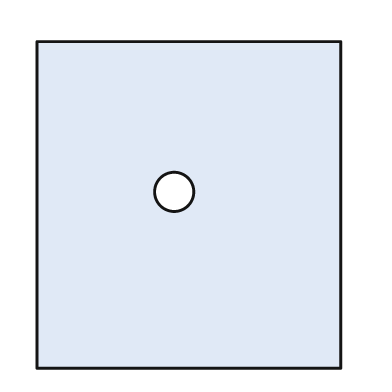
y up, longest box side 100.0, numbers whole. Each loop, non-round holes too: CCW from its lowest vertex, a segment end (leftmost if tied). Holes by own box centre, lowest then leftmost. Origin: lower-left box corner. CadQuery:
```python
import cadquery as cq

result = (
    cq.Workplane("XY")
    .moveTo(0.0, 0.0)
    .lineTo(93.0, 0.0)
    .lineTo(93.0, 100.0)
    .lineTo(0.0, 100.0)
    .close()
    .moveTo(42.0, 54.0)
    .circle(6.0)
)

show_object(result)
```